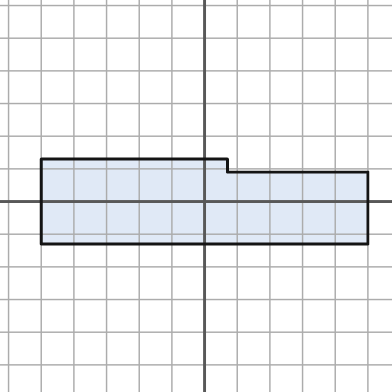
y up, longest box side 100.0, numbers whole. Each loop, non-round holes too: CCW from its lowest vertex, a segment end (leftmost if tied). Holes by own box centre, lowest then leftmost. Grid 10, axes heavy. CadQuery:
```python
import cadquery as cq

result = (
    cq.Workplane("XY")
    .moveTo(-50.0, -13.0)
    .lineTo(50.0, -13.0)
    .lineTo(50.0, 9.0)
    .lineTo(7.0, 9.0)
    .lineTo(7.0, 13.0)
    .lineTo(-50.0, 13.0)
    .close()
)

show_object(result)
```